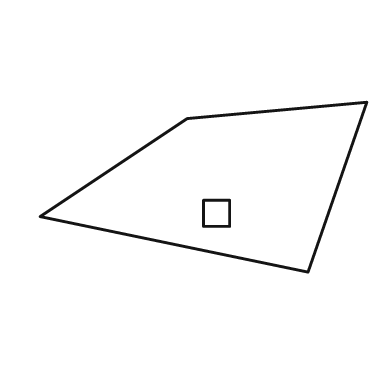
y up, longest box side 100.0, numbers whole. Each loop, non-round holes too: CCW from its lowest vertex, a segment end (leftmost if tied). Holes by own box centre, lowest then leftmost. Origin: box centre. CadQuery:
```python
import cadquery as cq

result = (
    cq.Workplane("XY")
    .moveTo(32.0, -26.0)
    .lineTo(50.0, 26.0)
    .lineTo(-5.0, 21.0)
    .lineTo(-50.0, -9.0)
    .close()
    .moveTo(0.0, -12.0)
    .lineTo(8.0, -12.0)
    .lineTo(8.0, -4.0)
    .lineTo(0.0, -4.0)
    .close()
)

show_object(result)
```